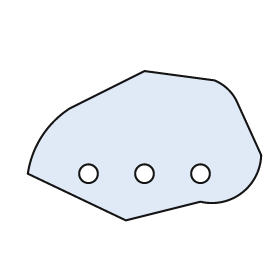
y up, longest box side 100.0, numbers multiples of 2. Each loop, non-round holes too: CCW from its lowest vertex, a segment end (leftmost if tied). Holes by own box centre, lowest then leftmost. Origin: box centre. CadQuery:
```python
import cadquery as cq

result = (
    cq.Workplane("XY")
    .moveTo(-8.0, -32.0)
    .lineTo(24.0, -24.0)
    .threePointArc((42.0, -20.0), (50.0, -4.0))
    .lineTo(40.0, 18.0)
    .threePointArc((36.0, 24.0), (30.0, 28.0))
    .lineTo(0.0, 32.0)
    .lineTo(-32.0, 16.0)
    .threePointArc((-44.0, 4.0), (-50.0, -12.0))
    .close()
    .moveTo(-24.0, -12.0)
    .circle(4.0)
    .moveTo(0.0, -12.0)
    .circle(4.0)
    .moveTo(24.0, -12.0)
    .circle(4.0)
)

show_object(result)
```